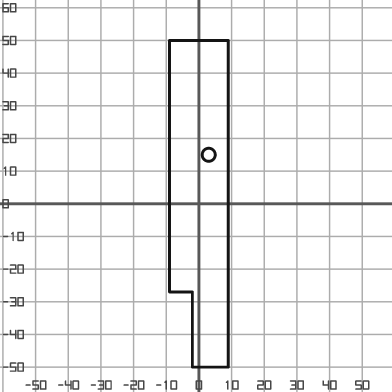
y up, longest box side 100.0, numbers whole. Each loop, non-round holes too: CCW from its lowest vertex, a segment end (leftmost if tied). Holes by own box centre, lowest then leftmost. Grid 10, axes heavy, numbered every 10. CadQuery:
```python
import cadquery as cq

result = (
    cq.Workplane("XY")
    .moveTo(-2.0, -50.0)
    .lineTo(9.0, -50.0)
    .lineTo(9.0, 50.0)
    .lineTo(-9.0, 50.0)
    .lineTo(-9.0, -27.0)
    .lineTo(-2.0, -27.0)
    .close()
    .moveTo(3.0, 15.0)
    .circle(2.0)
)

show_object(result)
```